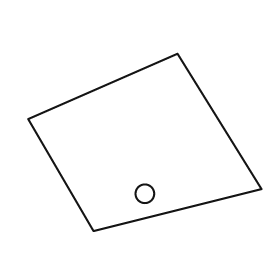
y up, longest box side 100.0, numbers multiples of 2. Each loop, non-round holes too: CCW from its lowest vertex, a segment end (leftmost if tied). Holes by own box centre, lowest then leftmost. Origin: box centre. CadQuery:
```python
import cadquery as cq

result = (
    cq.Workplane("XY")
    .moveTo(-22.0, -38.0)
    .lineTo(50.0, -20.0)
    .lineTo(14.0, 38.0)
    .lineTo(-50.0, 10.0)
    .close()
    .moveTo(0.0, -22.0)
    .circle(4.0)
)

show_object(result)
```